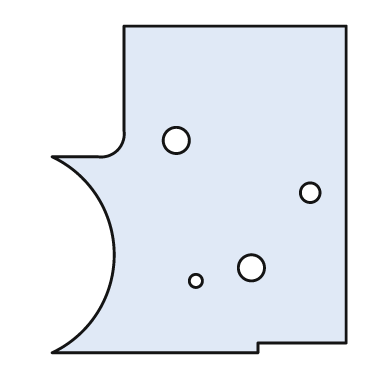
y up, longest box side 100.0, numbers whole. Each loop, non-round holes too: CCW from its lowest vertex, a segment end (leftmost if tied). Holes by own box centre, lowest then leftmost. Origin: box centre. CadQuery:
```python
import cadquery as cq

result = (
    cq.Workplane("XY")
    .moveTo(-45.0, -50.0)
    .lineTo(18.0, -50.0)
    .lineTo(18.0, -47.0)
    .lineTo(45.0, -47.0)
    .lineTo(45.0, 50.0)
    .lineTo(-23.0, 50.0)
    .lineTo(-23.0, 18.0)
    .threePointArc((-25.0, 12.0), (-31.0, 10.0))
    .lineTo(-45.0, 10.0)
    .threePointArc((-26.0, -20.0), (-45.0, -50.0))
    .close()
    .moveTo(-1.0, -28.0)
    .circle(2.0)
    .moveTo(16.0, -24.0)
    .circle(4.0)
    .moveTo(34.0, -1.0)
    .circle(3.0)
    .moveTo(-7.0, 15.0)
    .circle(4.0)
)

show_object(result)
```